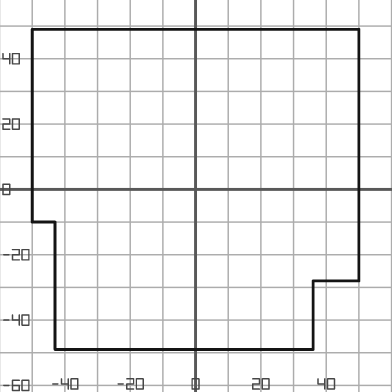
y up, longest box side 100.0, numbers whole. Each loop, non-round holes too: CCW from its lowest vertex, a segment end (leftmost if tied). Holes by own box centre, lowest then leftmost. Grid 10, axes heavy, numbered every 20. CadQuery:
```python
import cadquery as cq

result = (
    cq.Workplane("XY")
    .moveTo(-43.0, -49.0)
    .lineTo(36.0, -49.0)
    .lineTo(36.0, -28.0)
    .lineTo(50.0, -28.0)
    .lineTo(50.0, 49.0)
    .lineTo(-50.0, 49.0)
    .lineTo(-50.0, -10.0)
    .lineTo(-43.0, -10.0)
    .close()
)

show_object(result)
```